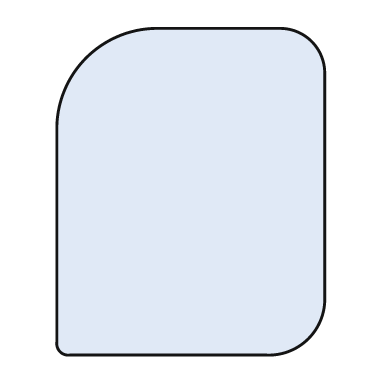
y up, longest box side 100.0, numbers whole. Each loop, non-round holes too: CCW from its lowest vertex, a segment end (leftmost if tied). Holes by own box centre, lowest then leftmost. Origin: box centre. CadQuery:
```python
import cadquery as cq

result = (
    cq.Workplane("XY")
    .moveTo(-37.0, -50.0)
    .lineTo(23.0, -50.0)
    .threePointArc((36.0, -45.0), (41.0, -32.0))
    .lineTo(41.0, 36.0)
    .threePointArc((37.0, 46.0), (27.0, 50.0))
    .lineTo(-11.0, 50.0)
    .threePointArc((-32.0, 41.0), (-41.0, 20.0))
    .lineTo(-41.0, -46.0)
    .threePointArc((-40.0, -49.0), (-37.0, -50.0))
    .close()
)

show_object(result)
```